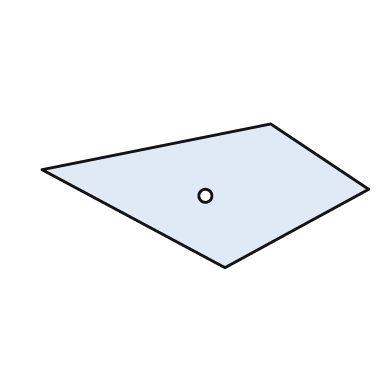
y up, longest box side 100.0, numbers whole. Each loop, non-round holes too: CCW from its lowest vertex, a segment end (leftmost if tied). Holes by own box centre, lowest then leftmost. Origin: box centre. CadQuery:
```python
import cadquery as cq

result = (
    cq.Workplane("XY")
    .moveTo(6.0, -22.0)
    .lineTo(50.0, 2.0)
    .lineTo(20.0, 22.0)
    .lineTo(-50.0, 8.0)
    .close()
    .moveTo(0.0, 0.0)
    .circle(2.0)
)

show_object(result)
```